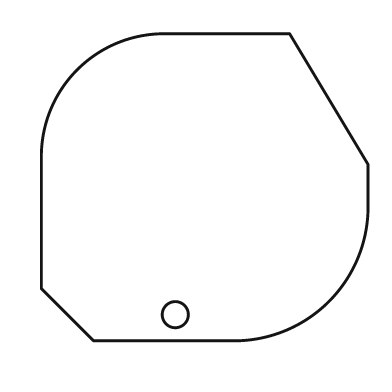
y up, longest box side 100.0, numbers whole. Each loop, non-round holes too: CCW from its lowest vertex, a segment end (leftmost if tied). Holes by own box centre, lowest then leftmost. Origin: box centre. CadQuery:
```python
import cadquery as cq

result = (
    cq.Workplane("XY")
    .moveTo(-34.0, -47.0)
    .lineTo(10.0, -47.0)
    .threePointArc((38.0, -35.0), (50.0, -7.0))
    .lineTo(50.0, 7.0)
    .lineTo(26.0, 47.0)
    .lineTo(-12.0, 47.0)
    .threePointArc((-39.0, 36.0), (-50.0, 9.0))
    .lineTo(-50.0, -31.0)
    .close()
    .moveTo(-9.0, -39.0)
    .circle(4.0)
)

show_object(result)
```